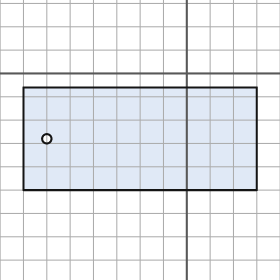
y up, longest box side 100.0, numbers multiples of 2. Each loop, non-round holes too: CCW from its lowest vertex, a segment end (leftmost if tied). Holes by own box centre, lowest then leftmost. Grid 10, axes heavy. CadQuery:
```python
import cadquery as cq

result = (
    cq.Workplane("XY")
    .moveTo(-70.0, -50.0)
    .lineTo(30.0, -50.0)
    .lineTo(30.0, -6.0)
    .lineTo(-70.0, -6.0)
    .close()
    .moveTo(-60.0, -28.0)
    .circle(2.0)
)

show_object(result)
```